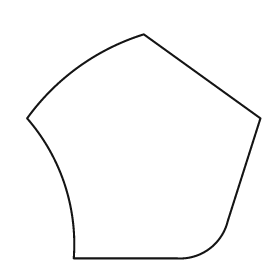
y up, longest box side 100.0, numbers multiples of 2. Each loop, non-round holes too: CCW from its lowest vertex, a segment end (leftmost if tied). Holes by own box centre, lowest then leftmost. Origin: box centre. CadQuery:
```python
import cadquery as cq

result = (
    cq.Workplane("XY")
    .moveTo(-30.0, -48.0)
    .lineTo(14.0, -48.0)
    .threePointArc((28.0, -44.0), (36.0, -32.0))
    .lineTo(50.0, 12.0)
    .lineTo(0.0, 48.0)
    .threePointArc((-28.0, 34.0), (-50.0, 12.0))
    .threePointArc((-34.0, -16.0), (-30.0, -48.0))
    .close()
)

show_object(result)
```